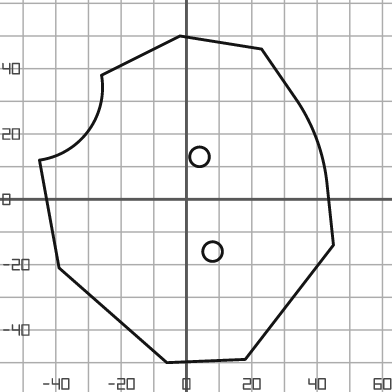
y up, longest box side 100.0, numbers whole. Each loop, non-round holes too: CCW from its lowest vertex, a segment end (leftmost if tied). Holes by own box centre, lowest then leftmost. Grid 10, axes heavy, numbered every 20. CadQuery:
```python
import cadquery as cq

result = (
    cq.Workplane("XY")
    .moveTo(-6.0, -50.0)
    .lineTo(18.0, -49.0)
    .lineTo(45.0, -14.0)
    .lineTo(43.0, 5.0)
    .threePointArc((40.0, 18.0), (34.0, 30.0))
    .lineTo(23.0, 46.0)
    .lineTo(-2.0, 50.0)
    .lineTo(-26.0, 38.0)
    .threePointArc((-30.0, 21.0), (-45.0, 12.0))
    .lineTo(-39.0, -21.0)
    .close()
    .moveTo(8.0, -16.0)
    .circle(3.0)
    .moveTo(4.0, 13.0)
    .circle(3.0)
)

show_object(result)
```